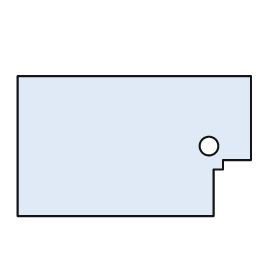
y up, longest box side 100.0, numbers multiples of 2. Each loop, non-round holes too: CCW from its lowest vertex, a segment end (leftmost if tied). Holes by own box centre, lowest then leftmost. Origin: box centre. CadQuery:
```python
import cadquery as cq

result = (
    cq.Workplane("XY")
    .moveTo(-50.0, -30.0)
    .lineTo(34.0, -30.0)
    .lineTo(34.0, -10.0)
    .lineTo(38.0, -10.0)
    .lineTo(38.0, -6.0)
    .lineTo(50.0, -6.0)
    .lineTo(50.0, 30.0)
    .lineTo(-50.0, 30.0)
    .close()
    .moveTo(32.0, 0.0)
    .circle(4.0)
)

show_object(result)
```